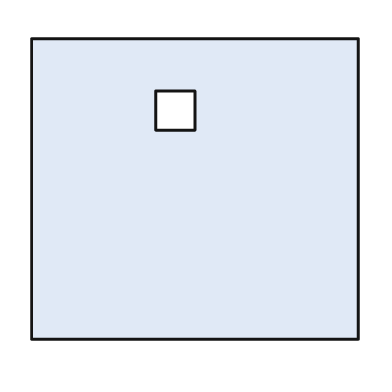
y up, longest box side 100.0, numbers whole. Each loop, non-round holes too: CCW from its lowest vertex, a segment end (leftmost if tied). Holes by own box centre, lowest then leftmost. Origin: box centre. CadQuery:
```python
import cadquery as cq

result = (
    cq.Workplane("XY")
    .moveTo(-50.0, -46.0)
    .lineTo(50.0, -46.0)
    .lineTo(50.0, 46.0)
    .lineTo(-50.0, 46.0)
    .close()
    .moveTo(-12.0, 18.0)
    .lineTo(0.0, 18.0)
    .lineTo(0.0, 30.0)
    .lineTo(-12.0, 30.0)
    .close()
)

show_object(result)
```